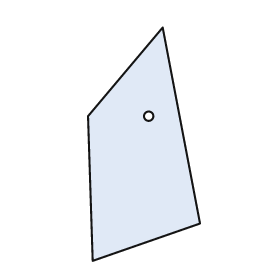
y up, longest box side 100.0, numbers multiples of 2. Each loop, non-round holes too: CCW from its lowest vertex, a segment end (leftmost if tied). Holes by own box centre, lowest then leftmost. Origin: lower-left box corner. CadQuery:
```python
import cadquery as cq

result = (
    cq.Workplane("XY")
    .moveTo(2.0, 0.0)
    .lineTo(48.0, 16.0)
    .lineTo(32.0, 100.0)
    .lineTo(0.0, 62.0)
    .close()
    .moveTo(26.0, 62.0)
    .circle(2.0)
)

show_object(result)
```